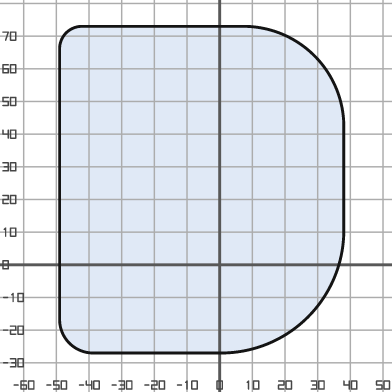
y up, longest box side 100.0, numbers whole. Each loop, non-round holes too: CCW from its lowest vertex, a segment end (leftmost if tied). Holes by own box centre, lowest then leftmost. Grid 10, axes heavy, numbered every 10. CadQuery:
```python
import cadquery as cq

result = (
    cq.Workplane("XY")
    .moveTo(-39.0, -27.0)
    .lineTo(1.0, -27.0)
    .threePointArc((27.0, -16.0), (38.0, 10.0))
    .lineTo(38.0, 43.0)
    .threePointArc((29.0, 64.0), (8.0, 73.0))
    .lineTo(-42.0, 73.0)
    .threePointArc((-47.0, 71.0), (-49.0, 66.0))
    .lineTo(-49.0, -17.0)
    .threePointArc((-46.0, -24.0), (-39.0, -27.0))
    .close()
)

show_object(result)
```